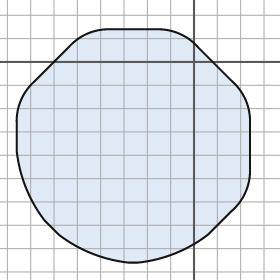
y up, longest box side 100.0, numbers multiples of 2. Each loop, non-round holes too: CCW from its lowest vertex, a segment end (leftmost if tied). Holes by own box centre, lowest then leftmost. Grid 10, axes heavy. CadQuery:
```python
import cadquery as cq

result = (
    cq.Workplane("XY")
    .moveTo(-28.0, -86.0)
    .lineTo(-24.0, -86.0)
    .threePointArc((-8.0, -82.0), (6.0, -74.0))
    .lineTo(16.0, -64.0)
    .threePointArc((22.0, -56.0), (24.0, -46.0))
    .lineTo(24.0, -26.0)
    .threePointArc((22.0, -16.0), (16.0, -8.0))
    .lineTo(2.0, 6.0)
    .threePointArc((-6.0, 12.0), (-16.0, 14.0))
    .lineTo(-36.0, 14.0)
    .threePointArc((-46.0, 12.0), (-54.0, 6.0))
    .lineTo(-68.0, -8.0)
    .threePointArc((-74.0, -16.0), (-76.0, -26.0))
    .lineTo(-76.0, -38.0)
    .threePointArc((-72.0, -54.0), (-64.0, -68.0))
    .lineTo(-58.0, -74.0)
    .threePointArc((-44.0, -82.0), (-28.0, -86.0))
    .close()
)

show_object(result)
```